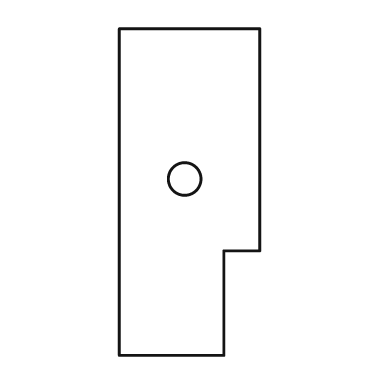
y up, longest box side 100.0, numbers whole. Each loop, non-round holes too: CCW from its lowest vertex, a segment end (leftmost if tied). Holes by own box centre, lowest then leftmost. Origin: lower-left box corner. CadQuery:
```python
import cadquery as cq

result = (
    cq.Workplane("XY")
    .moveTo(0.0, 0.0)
    .lineTo(32.0, 0.0)
    .lineTo(32.0, 32.0)
    .lineTo(43.0, 32.0)
    .lineTo(43.0, 100.0)
    .lineTo(0.0, 100.0)
    .close()
    .moveTo(20.0, 54.0)
    .circle(5.0)
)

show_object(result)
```